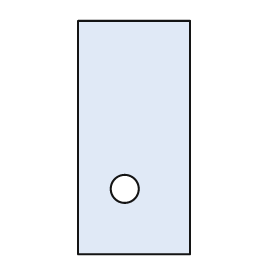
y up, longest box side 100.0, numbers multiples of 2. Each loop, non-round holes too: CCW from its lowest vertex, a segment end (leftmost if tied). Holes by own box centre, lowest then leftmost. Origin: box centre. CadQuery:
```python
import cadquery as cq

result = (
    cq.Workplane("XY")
    .moveTo(-24.0, -50.0)
    .lineTo(24.0, -50.0)
    .lineTo(24.0, 50.0)
    .lineTo(-24.0, 50.0)
    .close()
    .moveTo(-4.0, -22.0)
    .circle(6.0)
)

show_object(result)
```